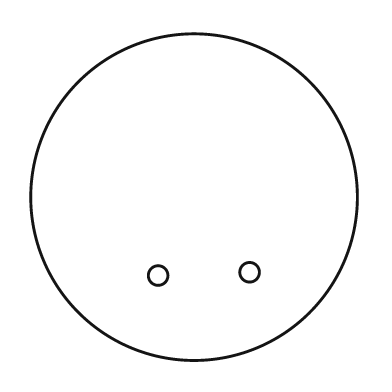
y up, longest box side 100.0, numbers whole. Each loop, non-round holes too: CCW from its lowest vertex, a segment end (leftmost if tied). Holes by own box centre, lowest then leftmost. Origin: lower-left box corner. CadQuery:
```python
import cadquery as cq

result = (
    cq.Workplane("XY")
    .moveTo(50.0, 50.0)
    .circle(50.0)
    .moveTo(39.0, 26.0)
    .circle(3.0)
    .moveTo(67.0, 27.0)
    .circle(3.0)
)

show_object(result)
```